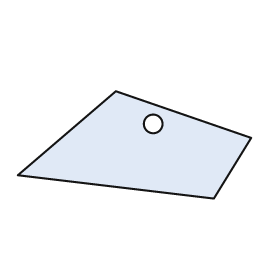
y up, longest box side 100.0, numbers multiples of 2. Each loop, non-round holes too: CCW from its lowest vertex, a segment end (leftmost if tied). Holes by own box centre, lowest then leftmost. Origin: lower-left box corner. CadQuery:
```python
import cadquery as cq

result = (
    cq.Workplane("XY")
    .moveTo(84.0, 0.0)
    .lineTo(100.0, 26.0)
    .lineTo(42.0, 46.0)
    .lineTo(0.0, 10.0)
    .close()
    .moveTo(58.0, 32.0)
    .circle(4.0)
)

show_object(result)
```